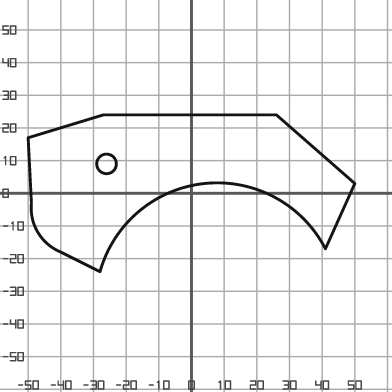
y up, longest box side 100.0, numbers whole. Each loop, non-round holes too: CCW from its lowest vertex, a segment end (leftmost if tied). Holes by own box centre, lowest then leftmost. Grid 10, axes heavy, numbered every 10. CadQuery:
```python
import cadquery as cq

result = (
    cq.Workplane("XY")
    .moveTo(-28.0, -24.0)
    .threePointArc((4.0, 3.0), (41.0, -17.0))
    .lineTo(50.0, 3.0)
    .lineTo(26.0, 24.0)
    .lineTo(-27.0, 24.0)
    .lineTo(-50.0, 17.0)
    .lineTo(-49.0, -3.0)
    .threePointArc((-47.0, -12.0), (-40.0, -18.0))
    .close()
    .moveTo(-26.0, 9.0)
    .circle(3.0)
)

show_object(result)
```